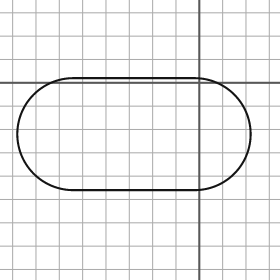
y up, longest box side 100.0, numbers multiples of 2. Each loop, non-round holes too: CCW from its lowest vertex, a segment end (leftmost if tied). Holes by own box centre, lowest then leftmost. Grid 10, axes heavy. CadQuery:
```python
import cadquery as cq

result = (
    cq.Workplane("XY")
    .moveTo(-54.0, -46.0)
    .lineTo(-2.0, -46.0)
    .threePointArc((22.0, -22.0), (-2.0, 2.0))
    .lineTo(-54.0, 2.0)
    .threePointArc((-78.0, -22.0), (-54.0, -46.0))
    .close()
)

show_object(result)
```